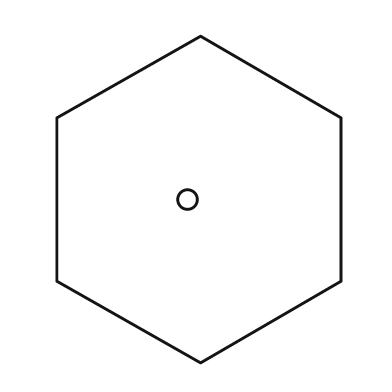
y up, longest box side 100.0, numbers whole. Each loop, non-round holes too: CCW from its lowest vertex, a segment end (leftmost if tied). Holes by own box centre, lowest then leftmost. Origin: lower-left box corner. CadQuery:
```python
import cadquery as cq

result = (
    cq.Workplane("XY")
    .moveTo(44.0, 0.0)
    .lineTo(87.0, 25.0)
    .lineTo(87.0, 75.0)
    .lineTo(44.0, 100.0)
    .lineTo(0.0, 75.0)
    .lineTo(0.0, 25.0)
    .close()
    .moveTo(40.0, 50.0)
    .circle(3.0)
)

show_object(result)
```